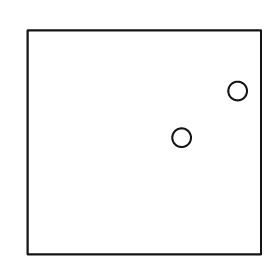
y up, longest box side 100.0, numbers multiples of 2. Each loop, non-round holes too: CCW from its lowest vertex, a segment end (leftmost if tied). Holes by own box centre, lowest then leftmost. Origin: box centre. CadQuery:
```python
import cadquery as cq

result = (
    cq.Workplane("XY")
    .moveTo(-50.0, -48.0)
    .lineTo(50.0, -48.0)
    .lineTo(50.0, 48.0)
    .lineTo(-50.0, 48.0)
    .close()
    .moveTo(16.0, 2.0)
    .circle(4.0)
    .moveTo(40.0, 22.0)
    .circle(4.0)
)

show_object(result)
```